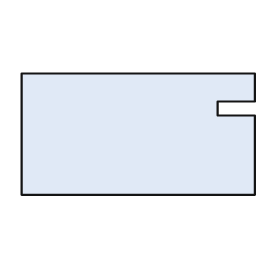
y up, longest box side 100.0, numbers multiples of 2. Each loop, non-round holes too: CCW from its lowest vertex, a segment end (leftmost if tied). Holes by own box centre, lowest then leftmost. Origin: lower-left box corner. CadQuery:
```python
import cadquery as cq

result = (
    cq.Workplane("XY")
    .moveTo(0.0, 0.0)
    .lineTo(100.0, 0.0)
    .lineTo(100.0, 34.0)
    .lineTo(84.0, 34.0)
    .lineTo(84.0, 40.0)
    .lineTo(100.0, 40.0)
    .lineTo(100.0, 52.0)
    .lineTo(0.0, 52.0)
    .close()
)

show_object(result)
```